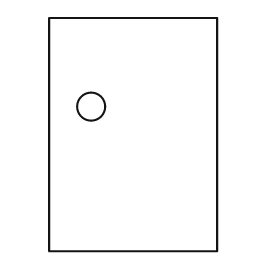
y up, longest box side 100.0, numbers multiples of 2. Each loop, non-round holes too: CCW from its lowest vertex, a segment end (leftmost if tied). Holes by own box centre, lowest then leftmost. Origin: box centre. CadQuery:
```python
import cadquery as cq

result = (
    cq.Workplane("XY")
    .moveTo(-36.0, -50.0)
    .lineTo(36.0, -50.0)
    .lineTo(36.0, 50.0)
    .lineTo(-36.0, 50.0)
    .close()
    .moveTo(-18.0, 12.0)
    .circle(6.0)
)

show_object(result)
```